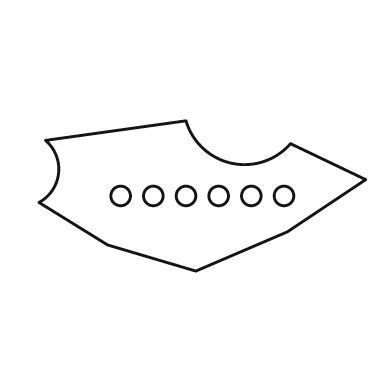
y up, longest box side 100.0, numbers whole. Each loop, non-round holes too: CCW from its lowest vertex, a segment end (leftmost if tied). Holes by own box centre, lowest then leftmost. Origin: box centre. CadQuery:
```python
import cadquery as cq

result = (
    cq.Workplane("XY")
    .moveTo(-2.0, -23.0)
    .lineTo(26.0, -11.0)
    .lineTo(50.0, 5.0)
    .lineTo(27.0, 16.0)
    .threePointArc((9.0, 10.0), (-5.0, 23.0))
    .lineTo(-48.0, 17.0)
    .threePointArc((-44.0, 7.0), (-50.0, -2.0))
    .lineTo(-29.0, -15.0)
    .close()
    .moveTo(-25.0, 0.0)
    .circle(3.0)
    .moveTo(-15.0, 0.0)
    .circle(3.0)
    .moveTo(-5.0, 0.0)
    .circle(3.0)
    .moveTo(5.0, 0.0)
    .circle(3.0)
    .moveTo(15.0, 0.0)
    .circle(3.0)
    .moveTo(25.0, 0.0)
    .circle(3.0)
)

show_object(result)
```